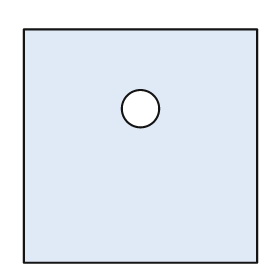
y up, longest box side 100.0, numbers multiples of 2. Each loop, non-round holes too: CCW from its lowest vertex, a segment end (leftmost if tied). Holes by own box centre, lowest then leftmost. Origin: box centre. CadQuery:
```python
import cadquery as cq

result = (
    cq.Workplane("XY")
    .moveTo(-50.0, -50.0)
    .lineTo(50.0, -50.0)
    .lineTo(50.0, 50.0)
    .lineTo(-50.0, 50.0)
    .close()
    .moveTo(0.0, 16.0)
    .circle(8.0)
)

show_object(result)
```